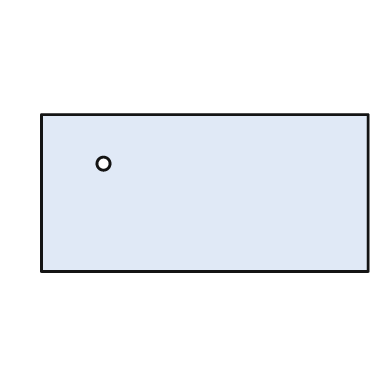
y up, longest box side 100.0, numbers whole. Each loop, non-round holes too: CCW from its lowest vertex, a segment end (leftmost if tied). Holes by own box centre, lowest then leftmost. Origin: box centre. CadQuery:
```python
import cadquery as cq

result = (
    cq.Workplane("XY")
    .moveTo(-50.0, -24.0)
    .lineTo(50.0, -24.0)
    .lineTo(50.0, 24.0)
    .lineTo(-50.0, 24.0)
    .close()
    .moveTo(-31.0, 9.0)
    .circle(2.0)
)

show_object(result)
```